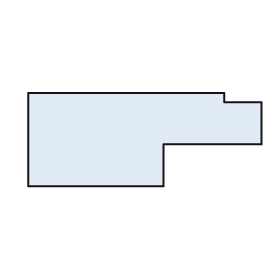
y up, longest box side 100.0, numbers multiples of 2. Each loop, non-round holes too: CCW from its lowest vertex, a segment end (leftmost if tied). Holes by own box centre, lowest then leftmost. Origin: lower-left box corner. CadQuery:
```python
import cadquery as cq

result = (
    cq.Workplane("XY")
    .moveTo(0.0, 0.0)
    .lineTo(58.0, 0.0)
    .lineTo(58.0, 18.0)
    .lineTo(100.0, 18.0)
    .lineTo(100.0, 36.0)
    .lineTo(84.0, 36.0)
    .lineTo(84.0, 40.0)
    .lineTo(0.0, 40.0)
    .close()
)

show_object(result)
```